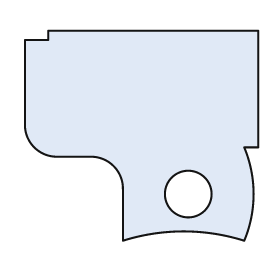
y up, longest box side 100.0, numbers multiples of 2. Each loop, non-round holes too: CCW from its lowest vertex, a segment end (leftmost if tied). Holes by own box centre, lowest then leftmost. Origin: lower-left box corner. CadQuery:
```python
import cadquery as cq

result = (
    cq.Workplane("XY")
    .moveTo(42.0, 0.0)
    .threePointArc((68.0, 4.0), (94.0, 0.0))
    .threePointArc((98.0, 20.0), (94.0, 40.0))
    .lineTo(100.0, 40.0)
    .lineTo(100.0, 90.0)
    .lineTo(10.0, 90.0)
    .lineTo(10.0, 86.0)
    .lineTo(0.0, 86.0)
    .lineTo(0.0, 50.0)
    .threePointArc((4.0, 40.0), (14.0, 36.0))
    .lineTo(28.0, 36.0)
    .threePointArc((38.0, 32.0), (42.0, 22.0))
    .close()
    .moveTo(70.0, 20.0)
    .circle(10.0)
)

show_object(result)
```